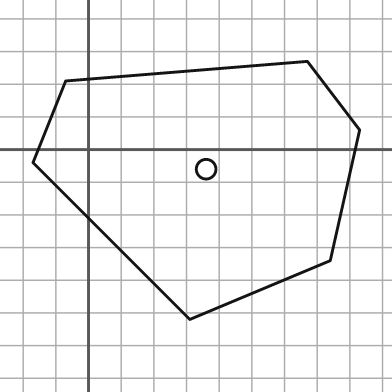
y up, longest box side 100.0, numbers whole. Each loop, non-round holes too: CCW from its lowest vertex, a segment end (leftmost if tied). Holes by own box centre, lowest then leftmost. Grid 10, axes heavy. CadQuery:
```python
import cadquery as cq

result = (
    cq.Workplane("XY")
    .moveTo(31.0, -52.0)
    .lineTo(74.0, -34.0)
    .lineTo(83.0, 6.0)
    .lineTo(67.0, 27.0)
    .lineTo(-7.0, 21.0)
    .lineTo(-17.0, -4.0)
    .close()
    .moveTo(36.0, -6.0)
    .circle(3.0)
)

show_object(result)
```